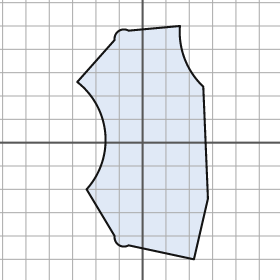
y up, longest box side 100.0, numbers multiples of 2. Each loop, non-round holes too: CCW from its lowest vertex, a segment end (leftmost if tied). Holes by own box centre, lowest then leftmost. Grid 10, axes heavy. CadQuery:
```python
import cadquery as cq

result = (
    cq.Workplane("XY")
    .moveTo(22.0, -50.0)
    .lineTo(28.0, -24.0)
    .lineTo(26.0, 24.0)
    .threePointArc((18.0, 36.0), (16.0, 50.0))
    .lineTo(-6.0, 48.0)
    .threePointArc((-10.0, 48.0), (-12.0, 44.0))
    .lineTo(-28.0, 26.0)
    .threePointArc((-16.0, 4.0), (-24.0, -20.0))
    .lineTo(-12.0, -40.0)
    .threePointArc((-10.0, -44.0), (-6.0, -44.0))
    .close()
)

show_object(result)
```